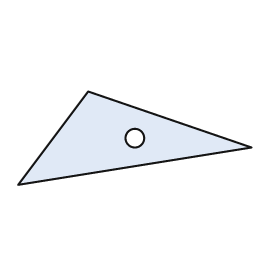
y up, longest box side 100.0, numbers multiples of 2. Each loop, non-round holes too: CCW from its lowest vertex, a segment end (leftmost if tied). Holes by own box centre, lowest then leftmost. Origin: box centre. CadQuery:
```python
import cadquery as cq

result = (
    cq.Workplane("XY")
    .moveTo(-50.0, -20.0)
    .lineTo(50.0, -4.0)
    .lineTo(-20.0, 20.0)
    .close()
    .moveTo(0.0, 0.0)
    .circle(4.0)
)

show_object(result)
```